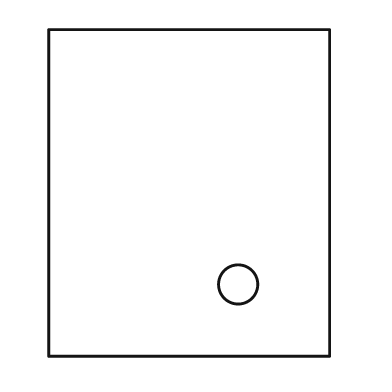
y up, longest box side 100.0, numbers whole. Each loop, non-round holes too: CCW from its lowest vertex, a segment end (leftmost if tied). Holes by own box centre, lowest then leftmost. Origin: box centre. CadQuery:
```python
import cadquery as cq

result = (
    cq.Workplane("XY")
    .moveTo(-43.0, -50.0)
    .lineTo(43.0, -50.0)
    .lineTo(43.0, 50.0)
    .lineTo(-43.0, 50.0)
    .close()
    .moveTo(15.0, -28.0)
    .circle(6.0)
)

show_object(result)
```